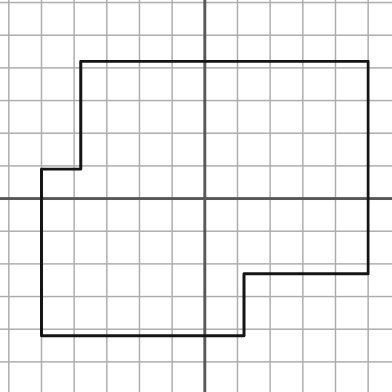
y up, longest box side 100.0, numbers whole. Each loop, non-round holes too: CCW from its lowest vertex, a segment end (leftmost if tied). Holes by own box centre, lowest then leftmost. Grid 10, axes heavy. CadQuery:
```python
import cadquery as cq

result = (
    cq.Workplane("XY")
    .moveTo(-50.0, -42.0)
    .lineTo(12.0, -42.0)
    .lineTo(12.0, -23.0)
    .lineTo(50.0, -23.0)
    .lineTo(50.0, 42.0)
    .lineTo(-38.0, 42.0)
    .lineTo(-38.0, 9.0)
    .lineTo(-50.0, 9.0)
    .close()
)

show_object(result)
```